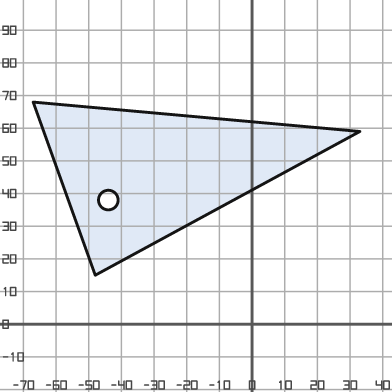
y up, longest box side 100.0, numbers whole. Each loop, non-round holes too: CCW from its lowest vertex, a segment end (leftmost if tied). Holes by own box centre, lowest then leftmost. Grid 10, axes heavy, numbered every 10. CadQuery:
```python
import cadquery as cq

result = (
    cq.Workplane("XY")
    .moveTo(-48.0, 15.0)
    .lineTo(33.0, 59.0)
    .lineTo(-67.0, 68.0)
    .close()
    .moveTo(-44.0, 38.0)
    .circle(3.0)
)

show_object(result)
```